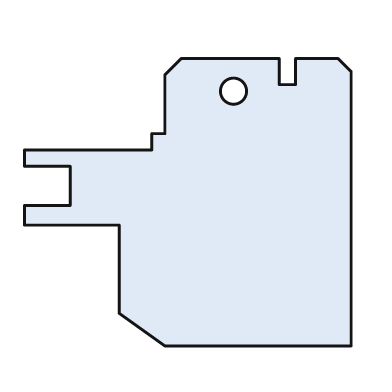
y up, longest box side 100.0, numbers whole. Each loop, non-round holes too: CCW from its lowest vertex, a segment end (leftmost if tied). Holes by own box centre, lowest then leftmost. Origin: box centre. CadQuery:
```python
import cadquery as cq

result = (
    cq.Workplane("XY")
    .moveTo(-7.0, -44.0)
    .lineTo(50.0, -44.0)
    .lineTo(50.0, 40.0)
    .lineTo(46.0, 44.0)
    .lineTo(33.0, 44.0)
    .lineTo(33.0, 36.0)
    .lineTo(28.0, 36.0)
    .lineTo(28.0, 44.0)
    .lineTo(-2.0, 44.0)
    .lineTo(-7.0, 39.0)
    .lineTo(-7.0, 21.0)
    .lineTo(-11.0, 21.0)
    .lineTo(-11.0, 16.0)
    .lineTo(-50.0, 16.0)
    .lineTo(-50.0, 11.0)
    .lineTo(-36.0, 11.0)
    .lineTo(-36.0, -1.0)
    .lineTo(-50.0, -1.0)
    .lineTo(-50.0, -7.0)
    .lineTo(-21.0, -7.0)
    .lineTo(-21.0, -34.0)
    .close()
    .moveTo(14.0, 34.0)
    .circle(4.0)
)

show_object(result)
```